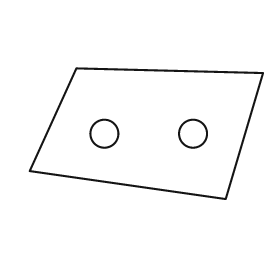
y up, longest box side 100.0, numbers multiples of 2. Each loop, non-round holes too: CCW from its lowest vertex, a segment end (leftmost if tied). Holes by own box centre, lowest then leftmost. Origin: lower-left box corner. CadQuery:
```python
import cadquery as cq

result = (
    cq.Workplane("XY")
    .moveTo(84.0, 0.0)
    .lineTo(100.0, 54.0)
    .lineTo(20.0, 56.0)
    .lineTo(0.0, 12.0)
    .close()
    .moveTo(32.0, 28.0)
    .circle(6.0)
    .moveTo(70.0, 28.0)
    .circle(6.0)
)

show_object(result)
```